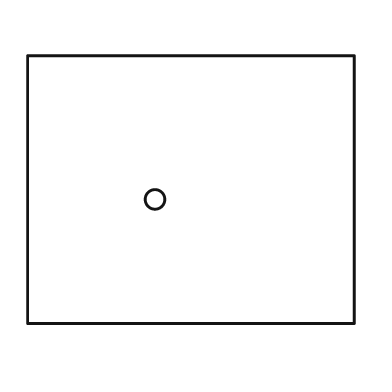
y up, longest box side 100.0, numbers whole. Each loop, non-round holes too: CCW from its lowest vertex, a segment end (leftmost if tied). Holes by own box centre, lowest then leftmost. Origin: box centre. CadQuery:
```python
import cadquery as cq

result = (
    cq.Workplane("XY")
    .moveTo(-50.0, -41.0)
    .lineTo(50.0, -41.0)
    .lineTo(50.0, 41.0)
    .lineTo(-50.0, 41.0)
    .close()
    .moveTo(-11.0, -3.0)
    .circle(3.0)
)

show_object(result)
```